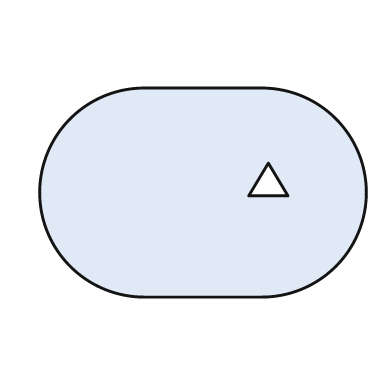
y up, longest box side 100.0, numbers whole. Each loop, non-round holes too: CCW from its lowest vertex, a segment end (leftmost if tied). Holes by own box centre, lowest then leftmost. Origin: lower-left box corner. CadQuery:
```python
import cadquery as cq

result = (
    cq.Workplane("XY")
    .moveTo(32.0, 0.0)
    .lineTo(68.0, 0.0)
    .threePointArc((100.0, 32.0), (68.0, 64.0))
    .lineTo(32.0, 64.0)
    .threePointArc((0.0, 32.0), (32.0, 0.0))
    .close()
    .moveTo(64.0, 31.0)
    .lineTo(76.0, 31.0)
    .lineTo(70.0, 41.0)
    .close()
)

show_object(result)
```